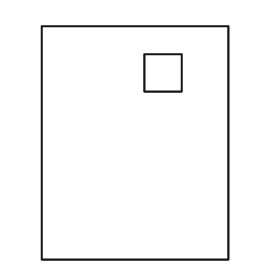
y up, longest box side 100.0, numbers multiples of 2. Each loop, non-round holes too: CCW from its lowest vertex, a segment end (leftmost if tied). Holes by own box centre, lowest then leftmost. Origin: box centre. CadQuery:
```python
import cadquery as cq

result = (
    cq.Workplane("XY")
    .moveTo(-40.0, -50.0)
    .lineTo(40.0, -50.0)
    .lineTo(40.0, 50.0)
    .lineTo(-40.0, 50.0)
    .close()
    .moveTo(4.0, 22.0)
    .lineTo(20.0, 22.0)
    .lineTo(20.0, 38.0)
    .lineTo(4.0, 38.0)
    .close()
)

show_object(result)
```